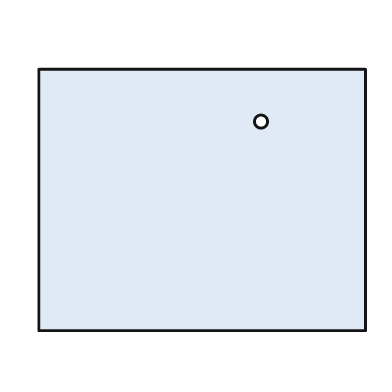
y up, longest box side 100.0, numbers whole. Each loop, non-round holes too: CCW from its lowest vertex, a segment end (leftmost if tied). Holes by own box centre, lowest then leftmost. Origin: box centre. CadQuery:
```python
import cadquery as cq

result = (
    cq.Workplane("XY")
    .moveTo(-50.0, -40.0)
    .lineTo(50.0, -40.0)
    .lineTo(50.0, 40.0)
    .lineTo(-50.0, 40.0)
    .close()
    .moveTo(18.0, 24.0)
    .circle(2.0)
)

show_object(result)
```